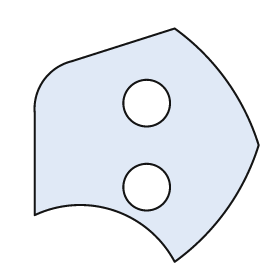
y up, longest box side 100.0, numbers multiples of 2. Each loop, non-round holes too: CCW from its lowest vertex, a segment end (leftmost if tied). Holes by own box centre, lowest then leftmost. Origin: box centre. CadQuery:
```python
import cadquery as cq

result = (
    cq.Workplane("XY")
    .moveTo(12.0, -50.0)
    .threePointArc((34.0, -28.0), (48.0, 0.0))
    .threePointArc((34.0, 28.0), (12.0, 50.0))
    .lineTo(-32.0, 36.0)
    .threePointArc((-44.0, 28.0), (-48.0, 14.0))
    .lineTo(-48.0, -30.0)
    .threePointArc((-14.0, -28.0), (12.0, -50.0))
    .close()
    .moveTo(0.0, -18.0)
    .circle(10.0)
    .moveTo(0.0, 18.0)
    .circle(10.0)
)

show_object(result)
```